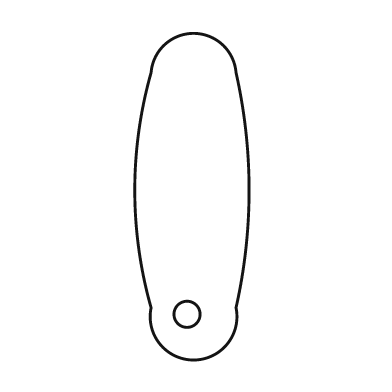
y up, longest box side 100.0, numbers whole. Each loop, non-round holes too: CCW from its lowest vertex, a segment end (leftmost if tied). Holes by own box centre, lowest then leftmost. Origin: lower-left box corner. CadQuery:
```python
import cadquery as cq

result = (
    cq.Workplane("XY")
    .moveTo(5.0, 16.0)
    .threePointArc((18.0, 0.0), (31.0, 16.0))
    .threePointArc((35.0, 52.0), (31.0, 88.0))
    .threePointArc((18.0, 100.0), (5.0, 88.0))
    .threePointArc((0.0, 52.0), (5.0, 16.0))
    .close()
    .moveTo(16.0, 14.0)
    .circle(4.0)
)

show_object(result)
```